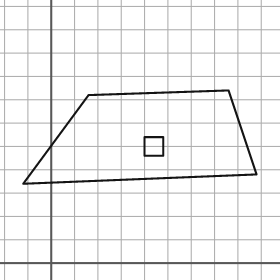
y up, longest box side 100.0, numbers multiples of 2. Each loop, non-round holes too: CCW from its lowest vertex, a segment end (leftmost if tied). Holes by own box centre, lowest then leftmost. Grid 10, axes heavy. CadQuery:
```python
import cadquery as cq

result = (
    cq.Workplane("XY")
    .moveTo(-12.0, 34.0)
    .lineTo(88.0, 38.0)
    .lineTo(76.0, 74.0)
    .lineTo(16.0, 72.0)
    .close()
    .moveTo(40.0, 46.0)
    .lineTo(48.0, 46.0)
    .lineTo(48.0, 54.0)
    .lineTo(40.0, 54.0)
    .close()
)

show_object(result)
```